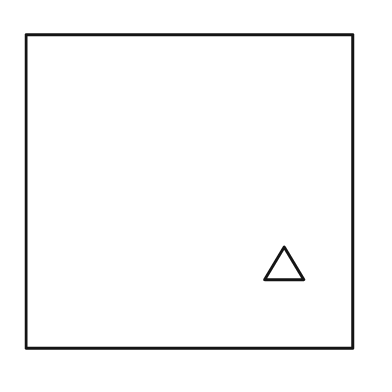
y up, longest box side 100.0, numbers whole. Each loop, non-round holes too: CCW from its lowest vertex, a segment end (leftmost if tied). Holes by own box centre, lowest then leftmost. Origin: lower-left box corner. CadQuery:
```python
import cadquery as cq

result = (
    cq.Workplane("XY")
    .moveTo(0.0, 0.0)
    .lineTo(100.0, 0.0)
    .lineTo(100.0, 96.0)
    .lineTo(0.0, 96.0)
    .close()
    .moveTo(73.0, 21.0)
    .lineTo(85.0, 21.0)
    .lineTo(79.0, 31.0)
    .close()
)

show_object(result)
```